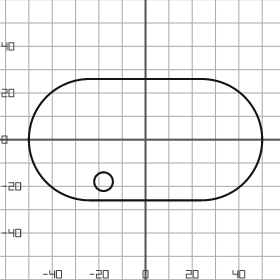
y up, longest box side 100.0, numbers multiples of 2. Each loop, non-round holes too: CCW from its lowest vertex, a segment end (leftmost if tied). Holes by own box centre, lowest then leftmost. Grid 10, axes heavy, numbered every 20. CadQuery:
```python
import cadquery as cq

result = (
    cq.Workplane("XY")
    .moveTo(-24.0, -26.0)
    .lineTo(24.0, -26.0)
    .threePointArc((50.0, 0.0), (24.0, 26.0))
    .lineTo(-24.0, 26.0)
    .threePointArc((-50.0, 0.0), (-24.0, -26.0))
    .close()
    .moveTo(-18.0, -18.0)
    .circle(4.0)
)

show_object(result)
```